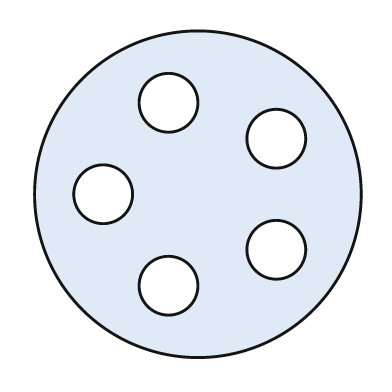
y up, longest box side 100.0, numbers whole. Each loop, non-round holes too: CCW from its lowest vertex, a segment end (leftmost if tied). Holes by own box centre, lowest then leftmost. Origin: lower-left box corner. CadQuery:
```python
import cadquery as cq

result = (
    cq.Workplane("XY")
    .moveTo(50.0, 50.0)
    .circle(50.0)
    .moveTo(41.0, 22.0)
    .circle(9.0)
    .moveTo(74.0, 33.0)
    .circle(9.0)
    .moveTo(21.0, 50.0)
    .circle(9.0)
    .moveTo(74.0, 67.0)
    .circle(9.0)
    .moveTo(41.0, 78.0)
    .circle(9.0)
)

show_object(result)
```